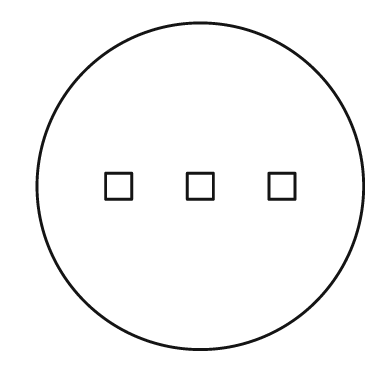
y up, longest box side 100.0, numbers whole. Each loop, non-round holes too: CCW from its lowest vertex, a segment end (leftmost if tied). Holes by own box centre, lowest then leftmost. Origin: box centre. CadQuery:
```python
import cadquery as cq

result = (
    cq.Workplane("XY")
    .moveTo(0.0, 0.0)
    .circle(50.0)
    .moveTo(-29.0, -4.0)
    .lineTo(-21.0, -4.0)
    .lineTo(-21.0, 4.0)
    .lineTo(-29.0, 4.0)
    .close()
    .moveTo(-4.0, -4.0)
    .lineTo(4.0, -4.0)
    .lineTo(4.0, 4.0)
    .lineTo(-4.0, 4.0)
    .close()
    .moveTo(21.0, -4.0)
    .lineTo(29.0, -4.0)
    .lineTo(29.0, 4.0)
    .lineTo(21.0, 4.0)
    .close()
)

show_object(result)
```